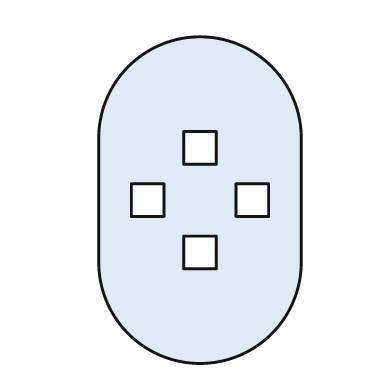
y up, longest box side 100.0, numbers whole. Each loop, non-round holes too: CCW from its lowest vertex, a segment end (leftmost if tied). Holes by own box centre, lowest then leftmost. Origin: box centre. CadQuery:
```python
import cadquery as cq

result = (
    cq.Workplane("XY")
    .moveTo(-31.0, -19.0)
    .threePointArc((0.0, -50.0), (31.0, -19.0))
    .lineTo(31.0, 19.0)
    .threePointArc((0.0, 50.0), (-31.0, 19.0))
    .close()
    .moveTo(-5.0, -21.0)
    .lineTo(5.0, -21.0)
    .lineTo(5.0, -11.0)
    .lineTo(-5.0, -11.0)
    .close()
    .moveTo(-21.0, -5.0)
    .lineTo(-11.0, -5.0)
    .lineTo(-11.0, 5.0)
    .lineTo(-21.0, 5.0)
    .close()
    .moveTo(11.0, -5.0)
    .lineTo(21.0, -5.0)
    .lineTo(21.0, 5.0)
    .lineTo(11.0, 5.0)
    .close()
    .moveTo(-5.0, 11.0)
    .lineTo(5.0, 11.0)
    .lineTo(5.0, 21.0)
    .lineTo(-5.0, 21.0)
    .close()
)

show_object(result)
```